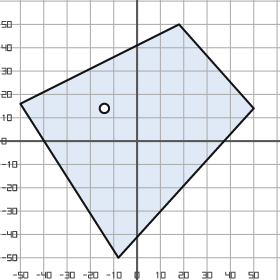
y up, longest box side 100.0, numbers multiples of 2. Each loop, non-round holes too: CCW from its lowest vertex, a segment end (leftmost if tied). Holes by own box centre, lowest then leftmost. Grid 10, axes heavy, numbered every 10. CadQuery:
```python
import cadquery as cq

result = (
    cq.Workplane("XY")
    .moveTo(-8.0, -50.0)
    .lineTo(50.0, 14.0)
    .lineTo(18.0, 50.0)
    .lineTo(-50.0, 16.0)
    .close()
    .moveTo(-14.0, 14.0)
    .circle(2.0)
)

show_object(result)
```